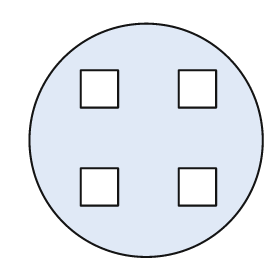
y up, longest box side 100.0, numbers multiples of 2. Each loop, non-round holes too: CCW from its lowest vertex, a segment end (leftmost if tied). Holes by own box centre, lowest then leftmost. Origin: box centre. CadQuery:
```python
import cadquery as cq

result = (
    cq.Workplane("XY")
    .moveTo(0.0, 0.0)
    .circle(50.0)
    .moveTo(-28.0, -28.0)
    .lineTo(-12.0, -28.0)
    .lineTo(-12.0, -12.0)
    .lineTo(-28.0, -12.0)
    .close()
    .moveTo(14.0, -28.0)
    .lineTo(30.0, -28.0)
    .lineTo(30.0, -12.0)
    .lineTo(14.0, -12.0)
    .close()
    .moveTo(-28.0, 14.0)
    .lineTo(-12.0, 14.0)
    .lineTo(-12.0, 30.0)
    .lineTo(-28.0, 30.0)
    .close()
    .moveTo(14.0, 14.0)
    .lineTo(30.0, 14.0)
    .lineTo(30.0, 30.0)
    .lineTo(14.0, 30.0)
    .close()
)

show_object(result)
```